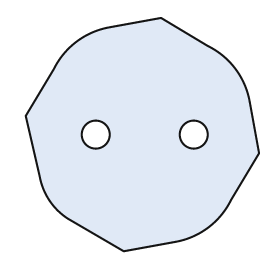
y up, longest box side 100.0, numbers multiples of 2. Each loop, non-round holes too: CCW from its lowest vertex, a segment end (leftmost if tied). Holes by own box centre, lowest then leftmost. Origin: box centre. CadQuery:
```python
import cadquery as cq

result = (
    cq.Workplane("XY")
    .moveTo(-8.0, -50.0)
    .lineTo(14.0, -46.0)
    .threePointArc((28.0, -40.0), (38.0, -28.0))
    .lineTo(50.0, -8.0)
    .lineTo(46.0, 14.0)
    .threePointArc((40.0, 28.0), (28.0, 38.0))
    .lineTo(8.0, 50.0)
    .lineTo(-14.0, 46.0)
    .threePointArc((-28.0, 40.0), (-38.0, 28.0))
    .lineTo(-50.0, 8.0)
    .lineTo(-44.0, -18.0)
    .threePointArc((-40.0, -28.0), (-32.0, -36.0))
    .close()
    .moveTo(-20.0, 0.0)
    .circle(6.0)
    .moveTo(22.0, 0.0)
    .circle(6.0)
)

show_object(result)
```